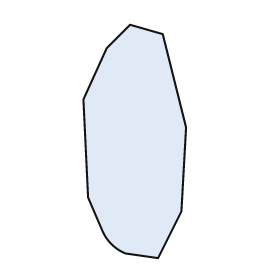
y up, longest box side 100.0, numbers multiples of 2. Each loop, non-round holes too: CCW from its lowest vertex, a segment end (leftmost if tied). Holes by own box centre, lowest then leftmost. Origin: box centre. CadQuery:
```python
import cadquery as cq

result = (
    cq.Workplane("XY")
    .moveTo(10.0, -50.0)
    .lineTo(20.0, -30.0)
    .lineTo(22.0, 6.0)
    .lineTo(12.0, 46.0)
    .lineTo(-2.0, 50.0)
    .lineTo(-12.0, 40.0)
    .lineTo(-22.0, 18.0)
    .lineTo(-20.0, -24.0)
    .lineTo(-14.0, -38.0)
    .threePointArc((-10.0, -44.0), (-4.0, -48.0))
    .close()
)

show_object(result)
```